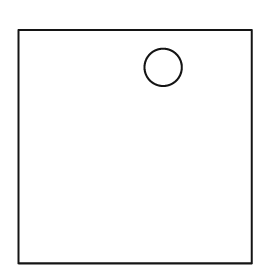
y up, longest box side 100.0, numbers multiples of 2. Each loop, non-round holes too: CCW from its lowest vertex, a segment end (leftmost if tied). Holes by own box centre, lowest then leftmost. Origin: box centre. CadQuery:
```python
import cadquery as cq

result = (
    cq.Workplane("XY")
    .moveTo(-50.0, -50.0)
    .lineTo(50.0, -50.0)
    .lineTo(50.0, 50.0)
    .lineTo(-50.0, 50.0)
    .close()
    .moveTo(12.0, 34.0)
    .circle(8.0)
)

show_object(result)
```